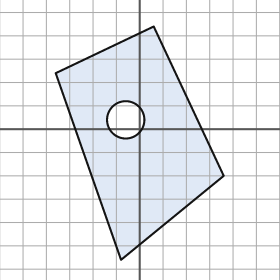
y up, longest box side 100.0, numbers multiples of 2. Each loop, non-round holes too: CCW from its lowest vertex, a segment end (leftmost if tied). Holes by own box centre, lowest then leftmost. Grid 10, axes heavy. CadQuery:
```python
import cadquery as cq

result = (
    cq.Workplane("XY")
    .moveTo(-8.0, -56.0)
    .lineTo(36.0, -20.0)
    .lineTo(6.0, 44.0)
    .lineTo(-36.0, 24.0)
    .close()
    .moveTo(-6.0, 4.0)
    .circle(8.0)
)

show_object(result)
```